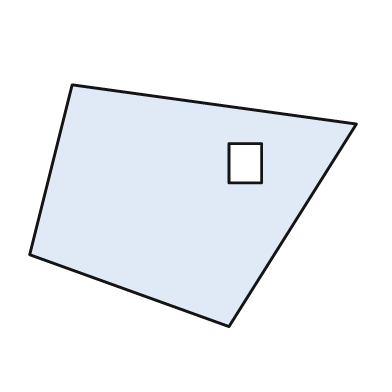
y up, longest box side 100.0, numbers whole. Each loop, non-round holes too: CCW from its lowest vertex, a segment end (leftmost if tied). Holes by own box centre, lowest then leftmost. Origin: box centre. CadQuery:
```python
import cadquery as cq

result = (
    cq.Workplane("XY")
    .moveTo(11.0, -37.0)
    .lineTo(50.0, 25.0)
    .lineTo(-37.0, 37.0)
    .lineTo(-50.0, -15.0)
    .close()
    .moveTo(11.0, 7.0)
    .lineTo(21.0, 7.0)
    .lineTo(21.0, 19.0)
    .lineTo(11.0, 19.0)
    .close()
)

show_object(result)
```